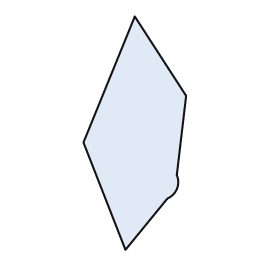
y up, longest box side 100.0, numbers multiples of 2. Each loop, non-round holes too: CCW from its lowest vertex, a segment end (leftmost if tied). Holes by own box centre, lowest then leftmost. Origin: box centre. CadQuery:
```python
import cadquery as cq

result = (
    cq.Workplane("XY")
    .moveTo(-4.0, -50.0)
    .lineTo(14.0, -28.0)
    .threePointArc((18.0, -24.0), (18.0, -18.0))
    .lineTo(22.0, 16.0)
    .lineTo(0.0, 50.0)
    .lineTo(-22.0, -4.0)
    .close()
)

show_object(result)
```